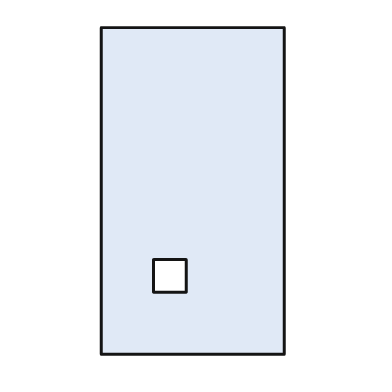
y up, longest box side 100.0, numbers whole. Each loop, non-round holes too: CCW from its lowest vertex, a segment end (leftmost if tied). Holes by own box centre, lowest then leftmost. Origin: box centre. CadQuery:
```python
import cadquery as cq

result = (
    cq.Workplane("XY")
    .moveTo(-28.0, -50.0)
    .lineTo(28.0, -50.0)
    .lineTo(28.0, 50.0)
    .lineTo(-28.0, 50.0)
    .close()
    .moveTo(-12.0, -31.0)
    .lineTo(-2.0, -31.0)
    .lineTo(-2.0, -21.0)
    .lineTo(-12.0, -21.0)
    .close()
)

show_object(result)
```